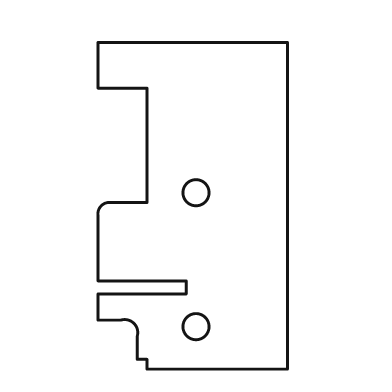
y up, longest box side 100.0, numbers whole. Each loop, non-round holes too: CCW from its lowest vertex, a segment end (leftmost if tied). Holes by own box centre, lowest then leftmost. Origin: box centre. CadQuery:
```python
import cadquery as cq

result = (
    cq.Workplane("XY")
    .moveTo(-14.0, -50.0)
    .lineTo(29.0, -50.0)
    .lineTo(29.0, 50.0)
    .lineTo(-29.0, 50.0)
    .lineTo(-29.0, 36.0)
    .lineTo(-14.0, 36.0)
    .lineTo(-14.0, 1.0)
    .lineTo(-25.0, 1.0)
    .threePointArc((-28.0, 0.0), (-29.0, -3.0))
    .lineTo(-29.0, -23.0)
    .lineTo(-2.0, -23.0)
    .lineTo(-2.0, -27.0)
    .lineTo(-29.0, -27.0)
    .lineTo(-29.0, -35.0)
    .lineTo(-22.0, -35.0)
    .threePointArc((-18.0, -36.0), (-17.0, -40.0))
    .lineTo(-17.0, -47.0)
    .lineTo(-14.0, -47.0)
    .close()
    .moveTo(1.0, -37.0)
    .circle(4.0)
    .moveTo(1.0, 4.0)
    .circle(4.0)
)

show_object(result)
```